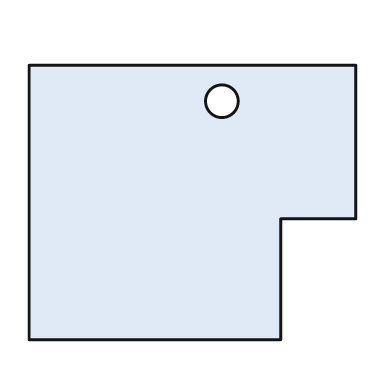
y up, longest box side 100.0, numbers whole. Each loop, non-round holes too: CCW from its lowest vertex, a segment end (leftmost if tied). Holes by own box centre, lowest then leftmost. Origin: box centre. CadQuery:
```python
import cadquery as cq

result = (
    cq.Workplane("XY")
    .moveTo(-50.0, -42.0)
    .lineTo(27.0, -42.0)
    .lineTo(27.0, -5.0)
    .lineTo(50.0, -5.0)
    .lineTo(50.0, 42.0)
    .lineTo(-50.0, 42.0)
    .close()
    .moveTo(9.0, 31.0)
    .circle(5.0)
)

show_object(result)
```